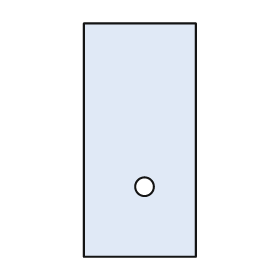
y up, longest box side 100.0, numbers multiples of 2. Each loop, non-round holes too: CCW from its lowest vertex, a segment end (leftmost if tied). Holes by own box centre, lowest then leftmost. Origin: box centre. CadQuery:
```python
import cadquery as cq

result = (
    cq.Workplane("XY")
    .moveTo(-24.0, -50.0)
    .lineTo(24.0, -50.0)
    .lineTo(24.0, 50.0)
    .lineTo(-24.0, 50.0)
    .close()
    .moveTo(2.0, -20.0)
    .circle(4.0)
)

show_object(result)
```